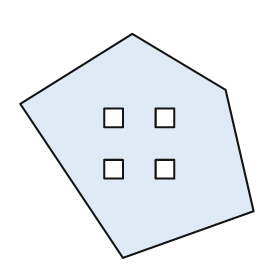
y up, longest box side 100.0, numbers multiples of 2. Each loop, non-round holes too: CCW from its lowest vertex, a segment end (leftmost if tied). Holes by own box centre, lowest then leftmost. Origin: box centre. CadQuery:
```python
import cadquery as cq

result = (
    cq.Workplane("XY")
    .moveTo(-6.0, -48.0)
    .lineTo(50.0, -28.0)
    .lineTo(38.0, 24.0)
    .lineTo(-2.0, 48.0)
    .lineTo(-50.0, 18.0)
    .close()
    .moveTo(-14.0, -14.0)
    .lineTo(-6.0, -14.0)
    .lineTo(-6.0, -6.0)
    .lineTo(-14.0, -6.0)
    .close()
    .moveTo(8.0, -14.0)
    .lineTo(16.0, -14.0)
    .lineTo(16.0, -6.0)
    .lineTo(8.0, -6.0)
    .close()
    .moveTo(-14.0, 8.0)
    .lineTo(-6.0, 8.0)
    .lineTo(-6.0, 16.0)
    .lineTo(-14.0, 16.0)
    .close()
    .moveTo(8.0, 8.0)
    .lineTo(16.0, 8.0)
    .lineTo(16.0, 16.0)
    .lineTo(8.0, 16.0)
    .close()
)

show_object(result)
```